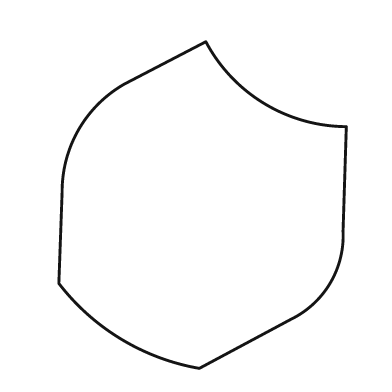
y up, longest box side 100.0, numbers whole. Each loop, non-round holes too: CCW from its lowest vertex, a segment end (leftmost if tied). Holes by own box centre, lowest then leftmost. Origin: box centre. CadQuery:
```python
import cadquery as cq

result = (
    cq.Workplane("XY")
    .moveTo(-1.0, -50.0)
    .lineTo(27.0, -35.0)
    .threePointArc((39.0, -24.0), (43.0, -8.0))
    .lineTo(44.0, 24.0)
    .threePointArc((19.0, 31.0), (1.0, 50.0))
    .lineTo(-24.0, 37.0)
    .threePointArc((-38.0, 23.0), (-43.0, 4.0))
    .lineTo(-44.0, -24.0)
    .threePointArc((-25.0, -41.0), (-1.0, -50.0))
    .close()
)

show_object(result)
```